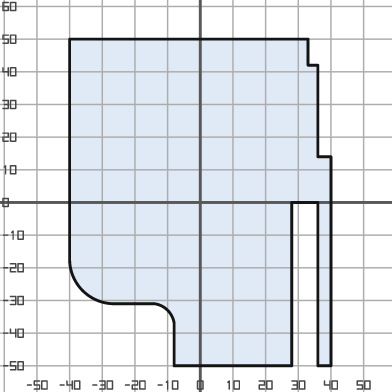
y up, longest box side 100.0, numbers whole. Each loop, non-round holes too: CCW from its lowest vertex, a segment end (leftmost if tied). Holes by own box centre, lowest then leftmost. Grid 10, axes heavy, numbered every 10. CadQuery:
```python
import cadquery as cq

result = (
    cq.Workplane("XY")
    .moveTo(-8.0, -50.0)
    .lineTo(28.0, -50.0)
    .lineTo(28.0, 0.0)
    .lineTo(36.0, 0.0)
    .lineTo(36.0, -50.0)
    .lineTo(40.0, -50.0)
    .lineTo(40.0, 14.0)
    .lineTo(36.0, 14.0)
    .lineTo(36.0, 42.0)
    .lineTo(33.0, 42.0)
    .lineTo(33.0, 50.0)
    .lineTo(-40.0, 50.0)
    .lineTo(-40.0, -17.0)
    .threePointArc((-36.0, -27.0), (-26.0, -31.0))
    .lineTo(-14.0, -31.0)
    .threePointArc((-10.0, -33.0), (-8.0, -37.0))
    .close()
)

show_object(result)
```